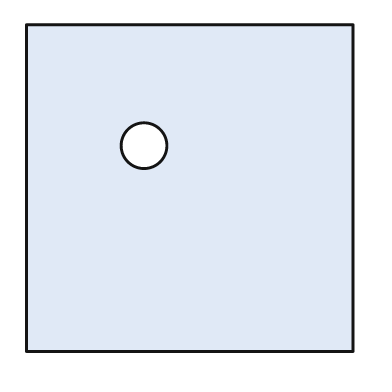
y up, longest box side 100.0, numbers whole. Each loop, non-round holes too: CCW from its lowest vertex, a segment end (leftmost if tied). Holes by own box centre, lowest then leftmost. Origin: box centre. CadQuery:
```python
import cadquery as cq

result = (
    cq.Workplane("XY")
    .moveTo(-50.0, -50.0)
    .lineTo(50.0, -50.0)
    .lineTo(50.0, 50.0)
    .lineTo(-50.0, 50.0)
    .close()
    .moveTo(-14.0, 13.0)
    .circle(7.0)
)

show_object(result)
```